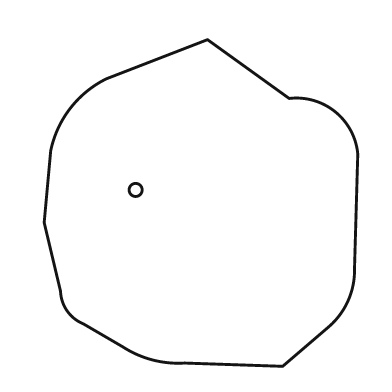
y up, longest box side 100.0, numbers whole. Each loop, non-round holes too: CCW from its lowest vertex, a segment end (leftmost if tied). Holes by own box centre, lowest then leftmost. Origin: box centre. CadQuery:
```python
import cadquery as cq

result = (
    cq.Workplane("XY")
    .moveTo(25.0, -50.0)
    .lineTo(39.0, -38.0)
    .threePointArc((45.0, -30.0), (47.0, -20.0))
    .lineTo(48.0, 15.0)
    .threePointArc((41.0, 28.0), (27.0, 32.0))
    .lineTo(2.0, 50.0)
    .lineTo(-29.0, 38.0)
    .threePointArc((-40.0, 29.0), (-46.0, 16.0))
    .lineTo(-48.0, -6.0)
    .lineTo(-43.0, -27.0)
    .threePointArc((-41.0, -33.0), (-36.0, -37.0))
    .lineTo(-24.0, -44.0)
    .threePointArc((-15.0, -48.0), (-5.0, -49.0))
    .close()
    .moveTo(-20.0, 4.0)
    .circle(2.0)
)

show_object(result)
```